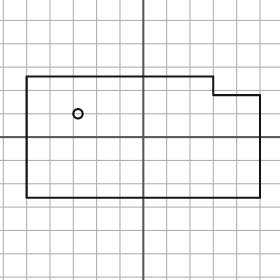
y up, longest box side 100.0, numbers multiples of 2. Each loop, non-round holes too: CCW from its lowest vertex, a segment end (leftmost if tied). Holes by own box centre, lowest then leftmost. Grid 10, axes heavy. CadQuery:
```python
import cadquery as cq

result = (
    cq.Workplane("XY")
    .moveTo(-50.0, -26.0)
    .lineTo(50.0, -26.0)
    .lineTo(50.0, 18.0)
    .lineTo(30.0, 18.0)
    .lineTo(30.0, 26.0)
    .lineTo(-50.0, 26.0)
    .close()
    .moveTo(-28.0, 10.0)
    .circle(2.0)
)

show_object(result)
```